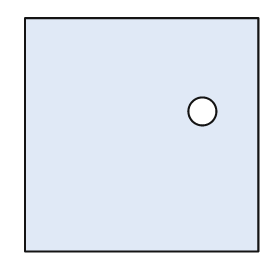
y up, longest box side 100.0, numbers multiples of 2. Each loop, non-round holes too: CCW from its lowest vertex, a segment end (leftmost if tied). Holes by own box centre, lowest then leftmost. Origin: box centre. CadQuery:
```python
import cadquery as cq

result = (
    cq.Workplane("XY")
    .moveTo(-50.0, -50.0)
    .lineTo(50.0, -50.0)
    .lineTo(50.0, 50.0)
    .lineTo(-50.0, 50.0)
    .close()
    .moveTo(26.0, 10.0)
    .circle(6.0)
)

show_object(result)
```